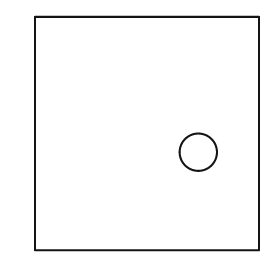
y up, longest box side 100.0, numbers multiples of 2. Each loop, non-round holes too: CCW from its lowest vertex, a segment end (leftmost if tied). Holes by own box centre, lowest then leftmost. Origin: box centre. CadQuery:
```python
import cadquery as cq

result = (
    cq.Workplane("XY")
    .moveTo(-48.0, -50.0)
    .lineTo(48.0, -50.0)
    .lineTo(48.0, 50.0)
    .lineTo(-48.0, 50.0)
    .close()
    .moveTo(22.0, -8.0)
    .circle(8.0)
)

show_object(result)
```